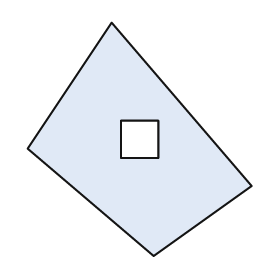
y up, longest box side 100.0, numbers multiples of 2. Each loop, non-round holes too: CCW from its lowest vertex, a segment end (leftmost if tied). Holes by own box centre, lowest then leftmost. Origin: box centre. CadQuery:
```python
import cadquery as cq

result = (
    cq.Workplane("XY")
    .moveTo(6.0, -50.0)
    .lineTo(48.0, -20.0)
    .lineTo(-12.0, 50.0)
    .lineTo(-48.0, -4.0)
    .close()
    .moveTo(-8.0, -8.0)
    .lineTo(8.0, -8.0)
    .lineTo(8.0, 8.0)
    .lineTo(-8.0, 8.0)
    .close()
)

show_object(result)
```